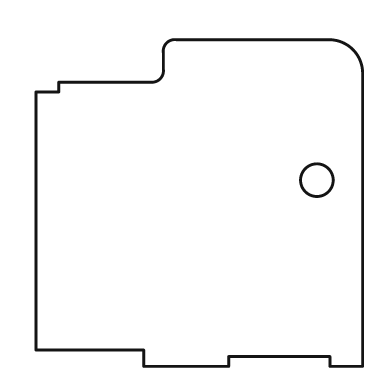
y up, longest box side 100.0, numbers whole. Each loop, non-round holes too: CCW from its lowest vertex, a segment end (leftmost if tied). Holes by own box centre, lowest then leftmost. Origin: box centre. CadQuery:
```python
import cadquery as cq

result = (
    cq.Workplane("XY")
    .moveTo(-17.0, -50.0)
    .lineTo(9.0, -50.0)
    .lineTo(9.0, -47.0)
    .lineTo(40.0, -47.0)
    .lineTo(40.0, -50.0)
    .lineTo(50.0, -50.0)
    .lineTo(50.0, 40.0)
    .threePointArc((47.0, 47.0), (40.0, 50.0))
    .lineTo(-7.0, 50.0)
    .threePointArc((-10.0, 49.0), (-11.0, 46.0))
    .lineTo(-11.0, 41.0)
    .threePointArc((-12.0, 38.0), (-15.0, 37.0))
    .lineTo(-43.0, 37.0)
    .lineTo(-43.0, 34.0)
    .lineTo(-50.0, 34.0)
    .lineTo(-50.0, -45.0)
    .lineTo(-17.0, -45.0)
    .close()
    .moveTo(36.0, 7.0)
    .circle(5.0)
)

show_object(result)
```